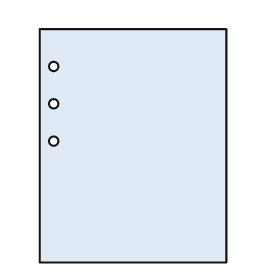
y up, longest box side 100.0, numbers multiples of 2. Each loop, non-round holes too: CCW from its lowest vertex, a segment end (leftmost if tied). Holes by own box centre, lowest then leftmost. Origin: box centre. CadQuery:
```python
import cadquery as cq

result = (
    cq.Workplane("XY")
    .moveTo(-40.0, -50.0)
    .lineTo(40.0, -50.0)
    .lineTo(40.0, 50.0)
    .lineTo(-40.0, 50.0)
    .close()
    .moveTo(-34.0, 2.0)
    .circle(2.0)
    .moveTo(-34.0, 18.0)
    .circle(2.0)
    .moveTo(-34.0, 34.0)
    .circle(2.0)
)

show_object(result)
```